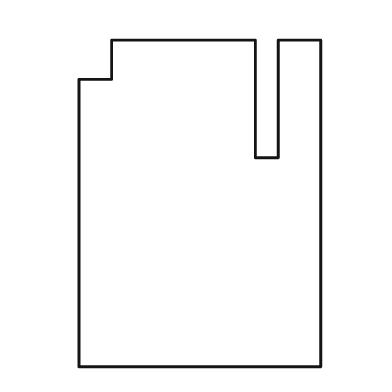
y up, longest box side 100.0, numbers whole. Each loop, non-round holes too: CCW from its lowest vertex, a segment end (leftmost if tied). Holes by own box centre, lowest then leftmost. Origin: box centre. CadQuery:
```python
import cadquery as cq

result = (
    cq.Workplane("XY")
    .moveTo(-37.0, -50.0)
    .lineTo(37.0, -50.0)
    .lineTo(37.0, 50.0)
    .lineTo(24.0, 50.0)
    .lineTo(24.0, 14.0)
    .lineTo(17.0, 14.0)
    .lineTo(17.0, 50.0)
    .lineTo(-27.0, 50.0)
    .lineTo(-27.0, 38.0)
    .lineTo(-37.0, 38.0)
    .close()
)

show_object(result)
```